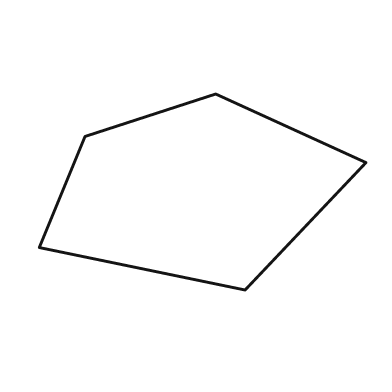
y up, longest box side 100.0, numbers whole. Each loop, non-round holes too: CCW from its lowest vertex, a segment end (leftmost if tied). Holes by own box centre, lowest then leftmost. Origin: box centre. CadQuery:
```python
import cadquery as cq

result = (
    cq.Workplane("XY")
    .moveTo(13.0, -30.0)
    .lineTo(50.0, 9.0)
    .lineTo(4.0, 30.0)
    .lineTo(-36.0, 17.0)
    .lineTo(-50.0, -17.0)
    .close()
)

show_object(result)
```